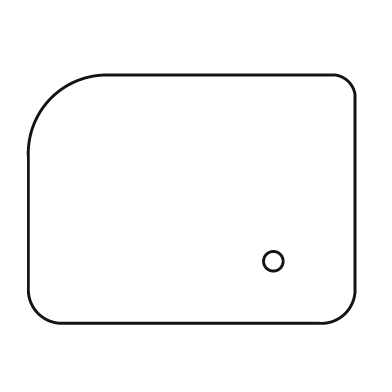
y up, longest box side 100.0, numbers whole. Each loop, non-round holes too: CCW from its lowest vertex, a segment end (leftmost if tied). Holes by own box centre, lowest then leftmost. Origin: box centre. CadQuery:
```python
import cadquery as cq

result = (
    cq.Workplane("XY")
    .moveTo(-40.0, -38.0)
    .lineTo(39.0, -38.0)
    .threePointArc((47.0, -35.0), (50.0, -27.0))
    .lineTo(50.0, 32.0)
    .threePointArc((48.0, 36.0), (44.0, 38.0))
    .lineTo(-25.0, 38.0)
    .threePointArc((-43.0, 31.0), (-50.0, 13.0))
    .lineTo(-50.0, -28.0)
    .threePointArc((-47.0, -35.0), (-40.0, -38.0))
    .close()
    .moveTo(25.0, -19.0)
    .circle(3.0)
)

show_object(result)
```